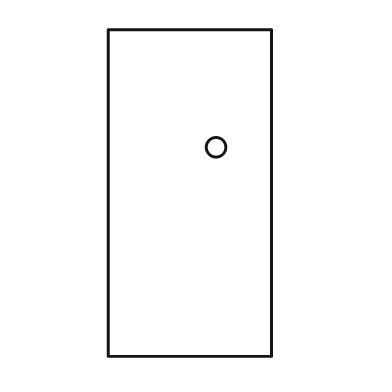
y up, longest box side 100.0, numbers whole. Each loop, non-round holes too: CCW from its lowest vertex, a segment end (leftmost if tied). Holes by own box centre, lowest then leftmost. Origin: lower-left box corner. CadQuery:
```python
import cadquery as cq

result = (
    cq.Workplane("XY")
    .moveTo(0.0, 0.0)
    .lineTo(50.0, 0.0)
    .lineTo(50.0, 100.0)
    .lineTo(0.0, 100.0)
    .close()
    .moveTo(33.0, 64.0)
    .circle(3.0)
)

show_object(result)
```